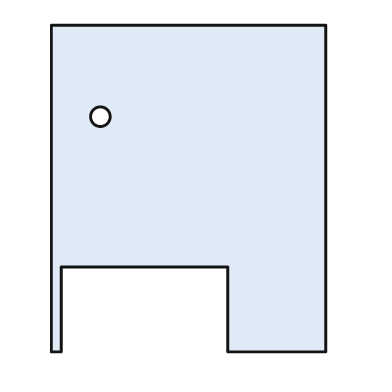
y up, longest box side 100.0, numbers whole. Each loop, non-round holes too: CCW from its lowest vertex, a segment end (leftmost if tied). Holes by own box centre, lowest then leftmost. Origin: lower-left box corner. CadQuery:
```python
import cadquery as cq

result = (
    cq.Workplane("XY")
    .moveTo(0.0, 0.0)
    .lineTo(3.0, 0.0)
    .lineTo(3.0, 26.0)
    .lineTo(54.0, 26.0)
    .lineTo(54.0, 0.0)
    .lineTo(84.0, 0.0)
    .lineTo(84.0, 100.0)
    .lineTo(0.0, 100.0)
    .close()
    .moveTo(15.0, 72.0)
    .circle(3.0)
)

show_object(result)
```